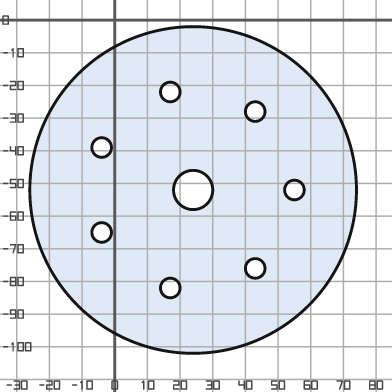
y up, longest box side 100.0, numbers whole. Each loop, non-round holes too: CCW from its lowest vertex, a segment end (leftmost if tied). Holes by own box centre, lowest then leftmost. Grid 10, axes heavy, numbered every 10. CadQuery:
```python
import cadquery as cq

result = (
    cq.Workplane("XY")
    .moveTo(24.0, -52.0)
    .circle(50.0)
    .moveTo(17.0, -82.0)
    .circle(3.0)
    .moveTo(43.0, -76.0)
    .circle(3.0)
    .moveTo(-4.0, -65.0)
    .circle(3.0)
    .moveTo(24.0, -52.0)
    .circle(6.0)
    .moveTo(55.0, -52.0)
    .circle(3.0)
    .moveTo(-4.0, -39.0)
    .circle(3.0)
    .moveTo(43.0, -28.0)
    .circle(3.0)
    .moveTo(17.0, -22.0)
    .circle(3.0)
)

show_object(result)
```